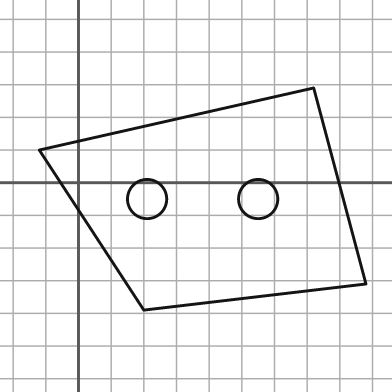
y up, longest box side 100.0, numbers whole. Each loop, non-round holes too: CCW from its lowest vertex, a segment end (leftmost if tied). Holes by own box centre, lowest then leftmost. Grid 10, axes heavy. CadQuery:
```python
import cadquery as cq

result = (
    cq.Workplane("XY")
    .moveTo(20.0, -39.0)
    .lineTo(88.0, -31.0)
    .lineTo(72.0, 29.0)
    .lineTo(-12.0, 10.0)
    .close()
    .moveTo(21.0, -5.0)
    .circle(6.0)
    .moveTo(55.0, -5.0)
    .circle(6.0)
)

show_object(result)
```